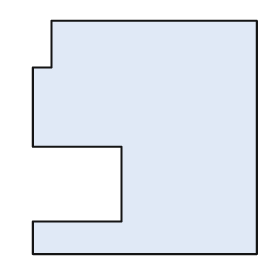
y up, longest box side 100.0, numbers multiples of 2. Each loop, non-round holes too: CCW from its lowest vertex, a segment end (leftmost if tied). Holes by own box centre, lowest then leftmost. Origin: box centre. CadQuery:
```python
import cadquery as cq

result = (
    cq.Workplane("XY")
    .moveTo(-48.0, -50.0)
    .lineTo(48.0, -50.0)
    .lineTo(48.0, 50.0)
    .lineTo(-40.0, 50.0)
    .lineTo(-40.0, 30.0)
    .lineTo(-48.0, 30.0)
    .lineTo(-48.0, -4.0)
    .lineTo(-10.0, -4.0)
    .lineTo(-10.0, -36.0)
    .lineTo(-48.0, -36.0)
    .close()
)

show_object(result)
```